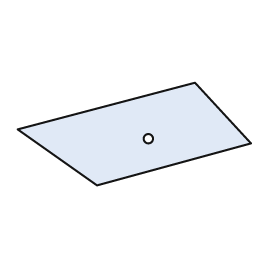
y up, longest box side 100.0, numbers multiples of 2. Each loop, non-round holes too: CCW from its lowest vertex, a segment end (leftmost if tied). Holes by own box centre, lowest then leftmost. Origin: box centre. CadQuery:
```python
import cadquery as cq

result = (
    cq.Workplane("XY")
    .moveTo(-16.0, -22.0)
    .lineTo(50.0, -4.0)
    .lineTo(26.0, 22.0)
    .lineTo(-50.0, 2.0)
    .close()
    .moveTo(6.0, -2.0)
    .circle(2.0)
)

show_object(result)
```